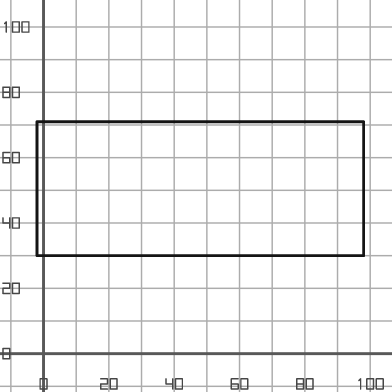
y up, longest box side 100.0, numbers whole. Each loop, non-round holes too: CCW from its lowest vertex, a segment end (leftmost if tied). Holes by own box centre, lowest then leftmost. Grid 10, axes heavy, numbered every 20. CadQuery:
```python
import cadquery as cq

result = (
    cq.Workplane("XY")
    .moveTo(-2.0, 30.0)
    .lineTo(98.0, 30.0)
    .lineTo(98.0, 71.0)
    .lineTo(-2.0, 71.0)
    .close()
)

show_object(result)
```